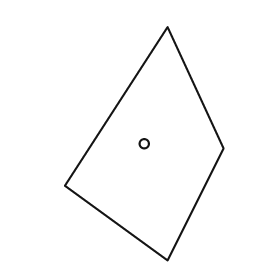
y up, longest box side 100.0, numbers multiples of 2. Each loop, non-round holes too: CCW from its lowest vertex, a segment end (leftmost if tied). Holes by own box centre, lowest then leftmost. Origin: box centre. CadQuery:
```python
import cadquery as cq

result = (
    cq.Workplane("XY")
    .moveTo(10.0, -50.0)
    .lineTo(34.0, -2.0)
    .lineTo(10.0, 50.0)
    .lineTo(-34.0, -18.0)
    .close()
    .moveTo(0.0, 0.0)
    .circle(2.0)
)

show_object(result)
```